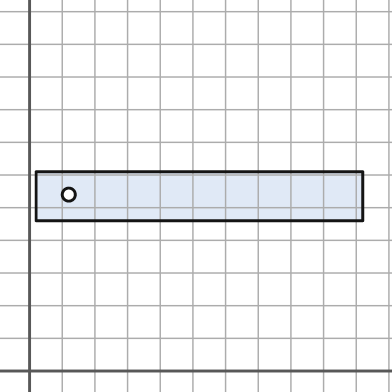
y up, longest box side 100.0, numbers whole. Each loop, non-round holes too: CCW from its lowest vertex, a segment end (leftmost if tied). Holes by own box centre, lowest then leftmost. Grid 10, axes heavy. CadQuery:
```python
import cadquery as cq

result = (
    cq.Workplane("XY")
    .moveTo(2.0, 46.0)
    .lineTo(102.0, 46.0)
    .lineTo(102.0, 61.0)
    .lineTo(2.0, 61.0)
    .close()
    .moveTo(12.0, 54.0)
    .circle(2.0)
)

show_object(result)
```